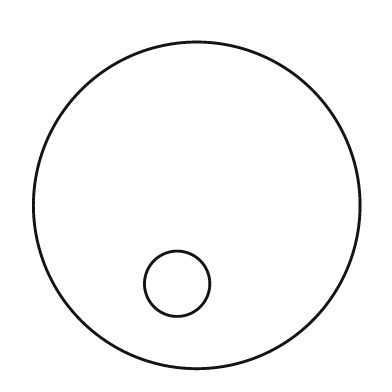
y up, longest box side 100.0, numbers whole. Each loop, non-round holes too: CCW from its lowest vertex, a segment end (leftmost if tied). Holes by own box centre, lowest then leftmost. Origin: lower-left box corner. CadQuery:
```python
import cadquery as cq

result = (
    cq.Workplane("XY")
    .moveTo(50.0, 50.0)
    .circle(50.0)
    .moveTo(44.0, 26.0)
    .circle(10.0)
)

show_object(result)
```